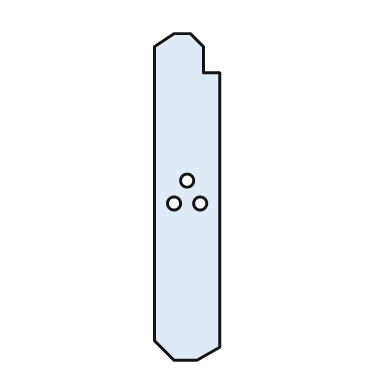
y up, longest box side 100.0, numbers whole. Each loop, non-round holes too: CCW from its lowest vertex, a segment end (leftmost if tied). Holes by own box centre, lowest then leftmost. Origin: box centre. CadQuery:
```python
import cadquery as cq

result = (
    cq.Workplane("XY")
    .moveTo(-4.0, -50.0)
    .lineTo(3.0, -50.0)
    .lineTo(10.0, -46.0)
    .lineTo(10.0, 38.0)
    .lineTo(5.0, 38.0)
    .lineTo(5.0, 46.0)
    .lineTo(1.0, 50.0)
    .lineTo(-4.0, 50.0)
    .lineTo(-10.0, 46.0)
    .lineTo(-10.0, -44.0)
    .close()
    .moveTo(-4.0, -2.0)
    .circle(2.0)
    .moveTo(4.0, -2.0)
    .circle(2.0)
    .moveTo(0.0, 5.0)
    .circle(2.0)
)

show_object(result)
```